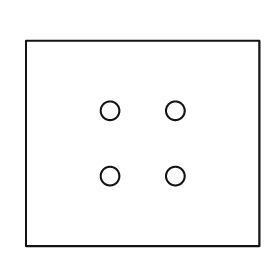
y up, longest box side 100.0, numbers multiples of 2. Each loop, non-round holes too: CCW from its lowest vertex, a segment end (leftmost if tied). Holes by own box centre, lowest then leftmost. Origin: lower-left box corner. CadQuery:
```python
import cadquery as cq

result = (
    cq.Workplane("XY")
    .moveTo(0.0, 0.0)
    .lineTo(100.0, 0.0)
    .lineTo(100.0, 88.0)
    .lineTo(0.0, 88.0)
    .close()
    .moveTo(36.0, 30.0)
    .circle(4.0)
    .moveTo(64.0, 30.0)
    .circle(4.0)
    .moveTo(36.0, 58.0)
    .circle(4.0)
    .moveTo(64.0, 58.0)
    .circle(4.0)
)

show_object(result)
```